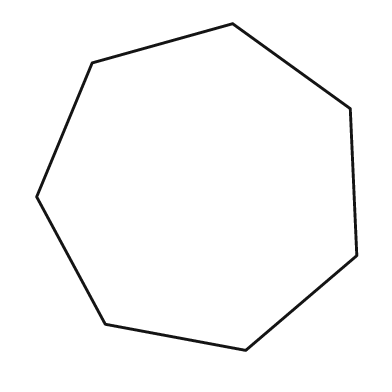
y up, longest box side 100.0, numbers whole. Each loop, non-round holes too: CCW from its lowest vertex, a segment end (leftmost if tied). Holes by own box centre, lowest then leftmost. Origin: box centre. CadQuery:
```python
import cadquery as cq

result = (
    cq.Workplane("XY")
    .moveTo(15.0, -50.0)
    .lineTo(49.0, -21.0)
    .lineTo(47.0, 24.0)
    .lineTo(11.0, 50.0)
    .lineTo(-32.0, 38.0)
    .lineTo(-49.0, -3.0)
    .lineTo(-28.0, -42.0)
    .close()
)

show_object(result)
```